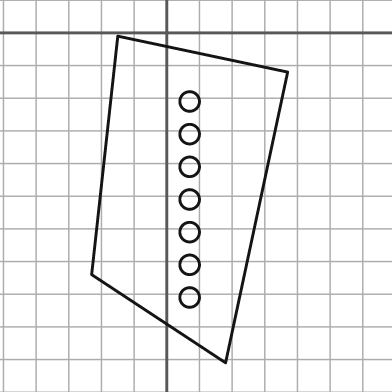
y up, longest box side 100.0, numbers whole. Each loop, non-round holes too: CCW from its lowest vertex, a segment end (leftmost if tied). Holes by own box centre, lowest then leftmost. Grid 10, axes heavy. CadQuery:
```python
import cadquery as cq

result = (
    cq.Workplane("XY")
    .moveTo(18.0, -101.0)
    .lineTo(37.0, -12.0)
    .lineTo(-15.0, -1.0)
    .lineTo(-23.0, -74.0)
    .close()
    .moveTo(7.0, -81.0)
    .circle(3.0)
    .moveTo(7.0, -71.0)
    .circle(3.0)
    .moveTo(7.0, -61.0)
    .circle(3.0)
    .moveTo(7.0, -51.0)
    .circle(3.0)
    .moveTo(7.0, -41.0)
    .circle(3.0)
    .moveTo(7.0, -31.0)
    .circle(3.0)
    .moveTo(7.0, -21.0)
    .circle(3.0)
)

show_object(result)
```